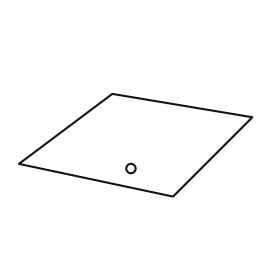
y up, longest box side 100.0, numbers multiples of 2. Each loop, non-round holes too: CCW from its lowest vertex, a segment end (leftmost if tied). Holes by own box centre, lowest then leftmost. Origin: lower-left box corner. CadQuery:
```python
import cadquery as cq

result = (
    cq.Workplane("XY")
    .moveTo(66.0, 0.0)
    .lineTo(100.0, 34.0)
    .lineTo(40.0, 44.0)
    .lineTo(0.0, 14.0)
    .close()
    .moveTo(48.0, 12.0)
    .circle(2.0)
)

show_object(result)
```